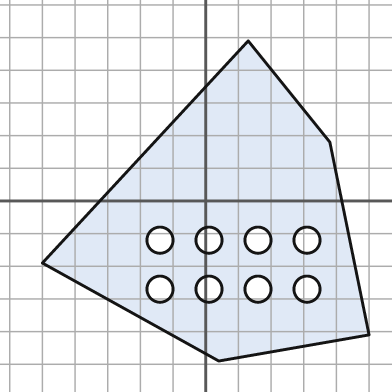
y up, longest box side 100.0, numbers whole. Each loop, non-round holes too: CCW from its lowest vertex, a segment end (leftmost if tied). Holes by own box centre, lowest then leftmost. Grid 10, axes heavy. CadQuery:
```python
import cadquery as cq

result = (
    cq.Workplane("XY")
    .moveTo(4.0, -49.0)
    .lineTo(50.0, -41.0)
    .lineTo(38.0, 18.0)
    .lineTo(13.0, 49.0)
    .lineTo(-50.0, -19.0)
    .close()
    .moveTo(-14.0, -27.0)
    .circle(4.0)
    .moveTo(1.0, -27.0)
    .circle(4.0)
    .moveTo(16.0, -27.0)
    .circle(4.0)
    .moveTo(31.0, -27.0)
    .circle(4.0)
    .moveTo(-14.0, -12.0)
    .circle(4.0)
    .moveTo(1.0, -12.0)
    .circle(4.0)
    .moveTo(16.0, -12.0)
    .circle(4.0)
    .moveTo(31.0, -12.0)
    .circle(4.0)
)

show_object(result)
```